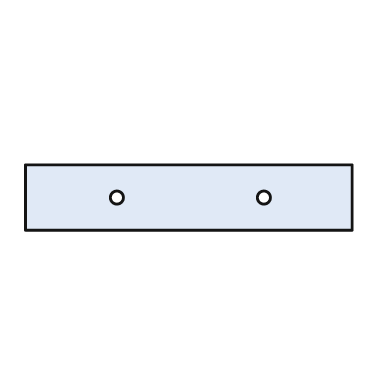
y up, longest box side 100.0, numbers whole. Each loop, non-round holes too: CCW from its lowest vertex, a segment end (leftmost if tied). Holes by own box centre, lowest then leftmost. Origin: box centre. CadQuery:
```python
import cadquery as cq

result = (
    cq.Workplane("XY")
    .moveTo(-50.0, -10.0)
    .lineTo(50.0, -10.0)
    .lineTo(50.0, 10.0)
    .lineTo(-50.0, 10.0)
    .close()
    .moveTo(-22.0, 0.0)
    .circle(2.0)
    .moveTo(23.0, 0.0)
    .circle(2.0)
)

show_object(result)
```